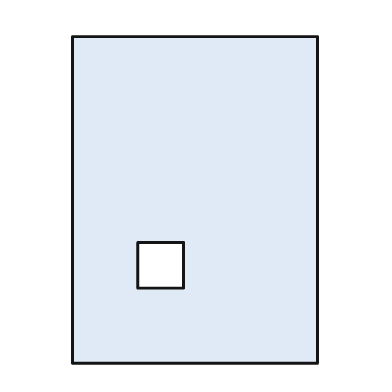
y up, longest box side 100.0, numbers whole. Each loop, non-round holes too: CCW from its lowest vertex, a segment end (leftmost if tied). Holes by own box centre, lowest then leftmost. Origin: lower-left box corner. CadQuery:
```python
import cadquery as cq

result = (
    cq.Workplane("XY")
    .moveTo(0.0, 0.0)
    .lineTo(75.0, 0.0)
    .lineTo(75.0, 100.0)
    .lineTo(0.0, 100.0)
    .close()
    .moveTo(20.0, 23.0)
    .lineTo(34.0, 23.0)
    .lineTo(34.0, 37.0)
    .lineTo(20.0, 37.0)
    .close()
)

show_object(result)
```